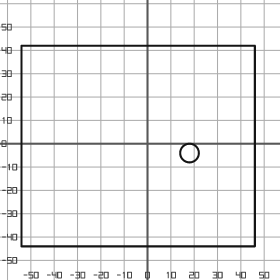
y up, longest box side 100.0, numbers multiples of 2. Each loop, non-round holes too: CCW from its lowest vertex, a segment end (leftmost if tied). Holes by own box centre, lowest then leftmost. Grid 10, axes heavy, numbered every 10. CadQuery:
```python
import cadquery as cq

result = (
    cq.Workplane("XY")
    .moveTo(-54.0, -44.0)
    .lineTo(46.0, -44.0)
    .lineTo(46.0, 42.0)
    .lineTo(-54.0, 42.0)
    .close()
    .moveTo(18.0, -4.0)
    .circle(4.0)
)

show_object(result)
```